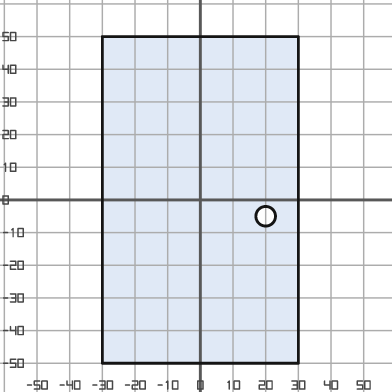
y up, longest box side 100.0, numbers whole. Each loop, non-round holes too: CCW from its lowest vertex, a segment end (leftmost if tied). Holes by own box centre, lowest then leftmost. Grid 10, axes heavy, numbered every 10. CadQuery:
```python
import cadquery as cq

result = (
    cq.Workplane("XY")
    .moveTo(-30.0, -50.0)
    .lineTo(30.0, -50.0)
    .lineTo(30.0, 50.0)
    .lineTo(-30.0, 50.0)
    .close()
    .moveTo(20.0, -5.0)
    .circle(3.0)
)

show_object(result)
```